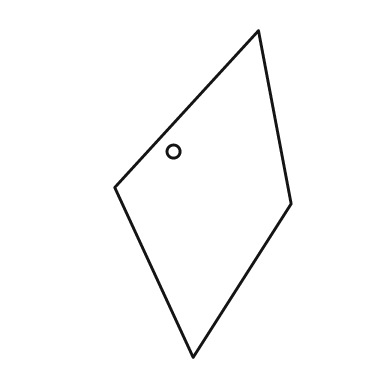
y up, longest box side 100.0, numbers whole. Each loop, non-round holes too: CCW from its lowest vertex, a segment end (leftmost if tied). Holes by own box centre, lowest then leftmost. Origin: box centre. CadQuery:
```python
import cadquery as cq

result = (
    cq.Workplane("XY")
    .moveTo(-3.0, -50.0)
    .lineTo(27.0, -3.0)
    .lineTo(17.0, 50.0)
    .lineTo(-27.0, 2.0)
    .close()
    .moveTo(-9.0, 13.0)
    .circle(2.0)
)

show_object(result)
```